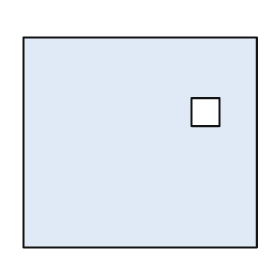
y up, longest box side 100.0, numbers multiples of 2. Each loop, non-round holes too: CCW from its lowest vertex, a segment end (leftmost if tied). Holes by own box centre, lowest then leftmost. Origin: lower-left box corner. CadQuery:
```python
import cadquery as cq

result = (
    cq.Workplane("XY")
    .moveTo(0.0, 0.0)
    .lineTo(100.0, 0.0)
    .lineTo(100.0, 90.0)
    .lineTo(0.0, 90.0)
    .close()
    .moveTo(72.0, 52.0)
    .lineTo(84.0, 52.0)
    .lineTo(84.0, 64.0)
    .lineTo(72.0, 64.0)
    .close()
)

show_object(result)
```